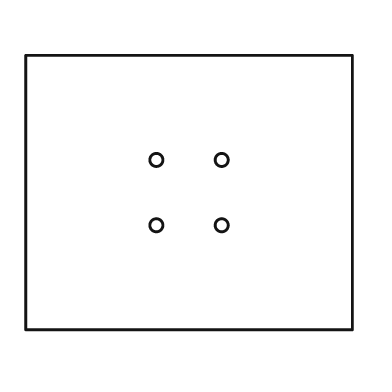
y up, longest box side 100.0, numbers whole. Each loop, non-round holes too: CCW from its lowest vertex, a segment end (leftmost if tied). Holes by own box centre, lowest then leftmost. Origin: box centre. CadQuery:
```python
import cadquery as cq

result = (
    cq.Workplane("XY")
    .moveTo(-50.0, -42.0)
    .lineTo(50.0, -42.0)
    .lineTo(50.0, 42.0)
    .lineTo(-50.0, 42.0)
    .close()
    .moveTo(-10.0, -10.0)
    .circle(2.0)
    .moveTo(10.0, -10.0)
    .circle(2.0)
    .moveTo(-10.0, 10.0)
    .circle(2.0)
    .moveTo(10.0, 10.0)
    .circle(2.0)
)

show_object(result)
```